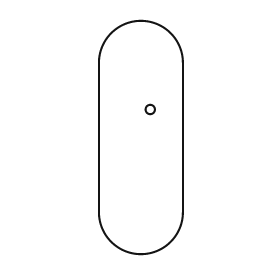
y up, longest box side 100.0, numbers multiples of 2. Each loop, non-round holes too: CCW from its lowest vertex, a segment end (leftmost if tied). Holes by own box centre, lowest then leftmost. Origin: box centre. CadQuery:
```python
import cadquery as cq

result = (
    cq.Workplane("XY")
    .moveTo(-18.0, -32.0)
    .threePointArc((0.0, -50.0), (18.0, -32.0))
    .lineTo(18.0, 32.0)
    .threePointArc((0.0, 50.0), (-18.0, 32.0))
    .close()
    .moveTo(4.0, 12.0)
    .circle(2.0)
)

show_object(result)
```